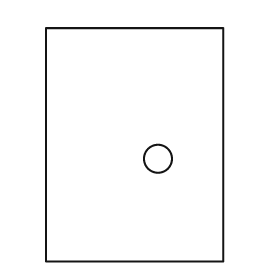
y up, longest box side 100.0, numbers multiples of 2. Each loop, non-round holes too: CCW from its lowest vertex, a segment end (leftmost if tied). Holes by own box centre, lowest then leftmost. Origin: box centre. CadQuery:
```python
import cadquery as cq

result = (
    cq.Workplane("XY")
    .moveTo(-38.0, -50.0)
    .lineTo(38.0, -50.0)
    .lineTo(38.0, 50.0)
    .lineTo(-38.0, 50.0)
    .close()
    .moveTo(10.0, -6.0)
    .circle(6.0)
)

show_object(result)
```